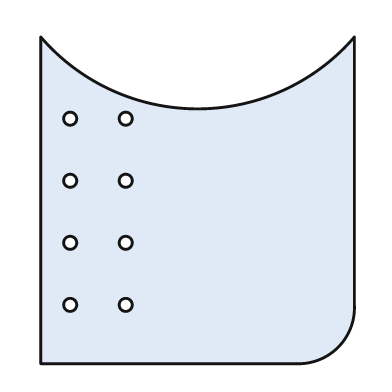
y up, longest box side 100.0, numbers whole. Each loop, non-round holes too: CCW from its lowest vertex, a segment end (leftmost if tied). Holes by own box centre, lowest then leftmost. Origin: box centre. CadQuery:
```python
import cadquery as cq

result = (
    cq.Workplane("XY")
    .moveTo(-48.0, -50.0)
    .lineTo(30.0, -50.0)
    .threePointArc((43.0, -45.0), (48.0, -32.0))
    .lineTo(48.0, 50.0)
    .threePointArc((0.0, 28.0), (-48.0, 50.0))
    .close()
    .moveTo(-39.0, -32.0)
    .circle(2.0)
    .moveTo(-22.0, -32.0)
    .circle(2.0)
    .moveTo(-39.0, -13.0)
    .circle(2.0)
    .moveTo(-22.0, -13.0)
    .circle(2.0)
    .moveTo(-39.0, 6.0)
    .circle(2.0)
    .moveTo(-22.0, 6.0)
    .circle(2.0)
    .moveTo(-39.0, 25.0)
    .circle(2.0)
    .moveTo(-22.0, 25.0)
    .circle(2.0)
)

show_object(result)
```